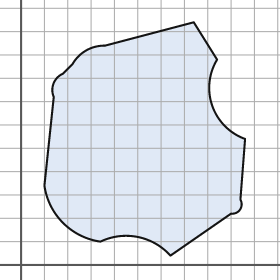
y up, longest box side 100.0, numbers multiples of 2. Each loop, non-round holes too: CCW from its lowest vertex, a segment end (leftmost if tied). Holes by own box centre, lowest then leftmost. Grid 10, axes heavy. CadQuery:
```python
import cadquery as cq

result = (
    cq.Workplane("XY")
    .moveTo(64.0, 4.0)
    .lineTo(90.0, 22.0)
    .threePointArc((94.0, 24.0), (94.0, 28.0))
    .lineTo(96.0, 54.0)
    .threePointArc((82.0, 68.0), (84.0, 88.0))
    .lineTo(74.0, 104.0)
    .lineTo(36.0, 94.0)
    .threePointArc((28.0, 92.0), (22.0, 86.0))
    .lineTo(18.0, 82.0)
    .threePointArc((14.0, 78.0), (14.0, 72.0))
    .lineTo(10.0, 34.0)
    .threePointArc((18.0, 18.0), (34.0, 10.0))
    .threePointArc((50.0, 12.0), (64.0, 4.0))
    .close()
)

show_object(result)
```